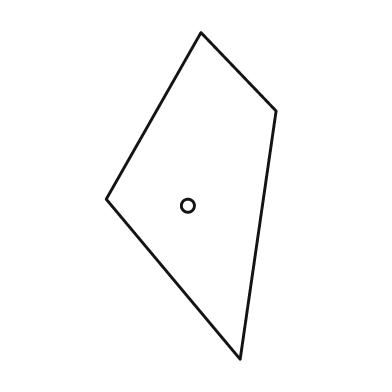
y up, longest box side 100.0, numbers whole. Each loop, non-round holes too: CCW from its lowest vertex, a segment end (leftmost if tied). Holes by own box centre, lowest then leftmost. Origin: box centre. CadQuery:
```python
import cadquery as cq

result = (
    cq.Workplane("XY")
    .moveTo(15.0, -50.0)
    .lineTo(26.0, 26.0)
    .lineTo(3.0, 50.0)
    .lineTo(-26.0, -1.0)
    .close()
    .moveTo(-1.0, -3.0)
    .circle(2.0)
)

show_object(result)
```